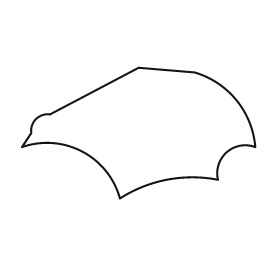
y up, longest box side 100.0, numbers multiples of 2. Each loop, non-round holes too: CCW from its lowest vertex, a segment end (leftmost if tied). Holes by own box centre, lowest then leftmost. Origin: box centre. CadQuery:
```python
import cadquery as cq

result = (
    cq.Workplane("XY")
    .moveTo(-8.0, -28.0)
    .threePointArc((12.0, -20.0), (34.0, -20.0))
    .threePointArc((38.0, -8.0), (50.0, -6.0))
    .threePointArc((42.0, 14.0), (24.0, 26.0))
    .lineTo(0.0, 28.0)
    .lineTo(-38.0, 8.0)
    .threePointArc((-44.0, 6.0), (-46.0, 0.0))
    .lineTo(-50.0, -6.0)
    .threePointArc((-24.0, -8.0), (-8.0, -28.0))
    .close()
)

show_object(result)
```